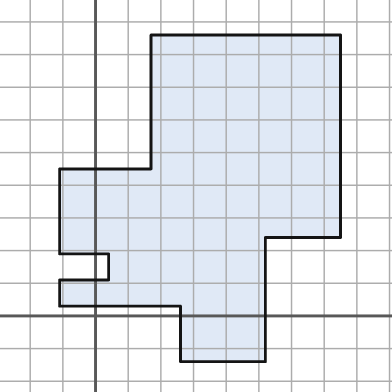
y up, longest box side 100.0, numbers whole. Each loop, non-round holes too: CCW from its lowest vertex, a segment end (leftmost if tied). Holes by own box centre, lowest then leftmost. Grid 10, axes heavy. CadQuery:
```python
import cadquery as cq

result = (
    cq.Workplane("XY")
    .moveTo(26.0, -14.0)
    .lineTo(52.0, -14.0)
    .lineTo(52.0, 24.0)
    .lineTo(75.0, 24.0)
    .lineTo(75.0, 86.0)
    .lineTo(17.0, 86.0)
    .lineTo(17.0, 45.0)
    .lineTo(-11.0, 45.0)
    .lineTo(-11.0, 19.0)
    .lineTo(4.0, 19.0)
    .lineTo(4.0, 11.0)
    .lineTo(-11.0, 11.0)
    .lineTo(-11.0, 3.0)
    .lineTo(26.0, 3.0)
    .close()
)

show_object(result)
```